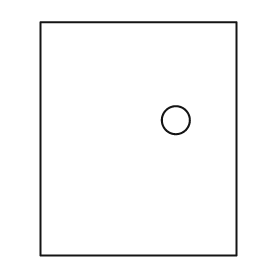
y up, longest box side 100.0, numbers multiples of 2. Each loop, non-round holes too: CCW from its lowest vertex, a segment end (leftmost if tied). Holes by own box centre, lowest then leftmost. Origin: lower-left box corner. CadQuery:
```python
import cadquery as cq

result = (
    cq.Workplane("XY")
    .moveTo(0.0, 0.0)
    .lineTo(84.0, 0.0)
    .lineTo(84.0, 100.0)
    .lineTo(0.0, 100.0)
    .close()
    .moveTo(58.0, 58.0)
    .circle(6.0)
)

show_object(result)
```